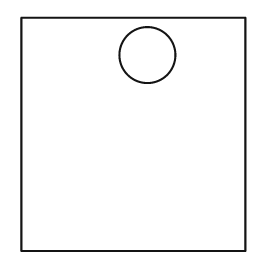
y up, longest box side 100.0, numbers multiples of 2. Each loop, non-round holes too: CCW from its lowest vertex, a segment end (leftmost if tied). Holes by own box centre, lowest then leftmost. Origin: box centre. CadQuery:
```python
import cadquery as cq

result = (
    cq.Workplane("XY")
    .moveTo(-48.0, -50.0)
    .lineTo(48.0, -50.0)
    .lineTo(48.0, 50.0)
    .lineTo(-48.0, 50.0)
    .close()
    .moveTo(6.0, 34.0)
    .circle(12.0)
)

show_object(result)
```